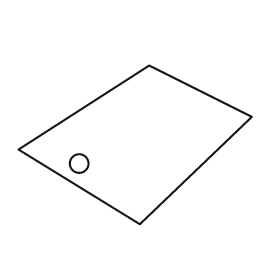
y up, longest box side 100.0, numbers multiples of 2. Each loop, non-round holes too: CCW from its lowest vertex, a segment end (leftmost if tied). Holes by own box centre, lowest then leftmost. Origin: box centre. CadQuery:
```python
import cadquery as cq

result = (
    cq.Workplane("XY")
    .moveTo(2.0, -34.0)
    .lineTo(50.0, 12.0)
    .lineTo(6.0, 34.0)
    .lineTo(-50.0, -2.0)
    .close()
    .moveTo(-24.0, -8.0)
    .circle(4.0)
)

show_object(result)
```